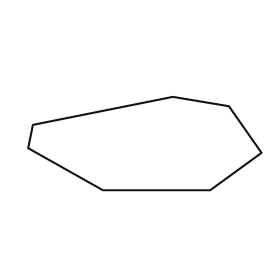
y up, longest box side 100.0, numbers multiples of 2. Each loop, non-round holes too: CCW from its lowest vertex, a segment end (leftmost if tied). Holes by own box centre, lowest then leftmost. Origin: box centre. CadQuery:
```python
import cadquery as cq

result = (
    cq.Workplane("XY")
    .moveTo(-18.0, -20.0)
    .lineTo(28.0, -20.0)
    .lineTo(50.0, -4.0)
    .lineTo(36.0, 16.0)
    .lineTo(12.0, 20.0)
    .lineTo(-48.0, 8.0)
    .lineTo(-50.0, -2.0)
    .close()
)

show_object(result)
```